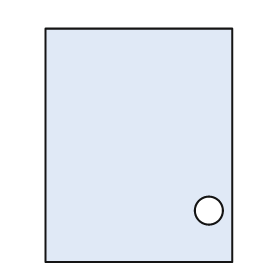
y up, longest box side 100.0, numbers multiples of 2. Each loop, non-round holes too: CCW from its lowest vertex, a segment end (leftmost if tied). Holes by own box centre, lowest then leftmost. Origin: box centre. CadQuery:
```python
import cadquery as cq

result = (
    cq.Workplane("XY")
    .moveTo(-40.0, -50.0)
    .lineTo(40.0, -50.0)
    .lineTo(40.0, 50.0)
    .lineTo(-40.0, 50.0)
    .close()
    .moveTo(30.0, -28.0)
    .circle(6.0)
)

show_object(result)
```